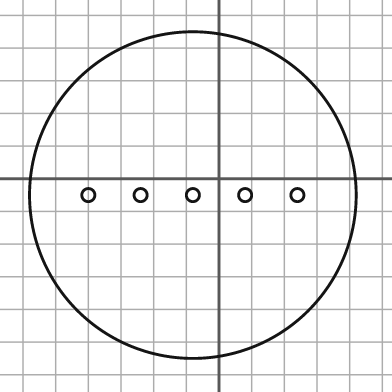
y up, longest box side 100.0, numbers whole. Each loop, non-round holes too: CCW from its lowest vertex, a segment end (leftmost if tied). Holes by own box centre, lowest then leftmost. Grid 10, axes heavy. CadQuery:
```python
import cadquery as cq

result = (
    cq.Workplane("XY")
    .moveTo(-8.0, -5.0)
    .circle(50.0)
    .moveTo(-40.0, -5.0)
    .circle(2.0)
    .moveTo(-24.0, -5.0)
    .circle(2.0)
    .moveTo(-8.0, -5.0)
    .circle(2.0)
    .moveTo(8.0, -5.0)
    .circle(2.0)
    .moveTo(24.0, -5.0)
    .circle(2.0)
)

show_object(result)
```